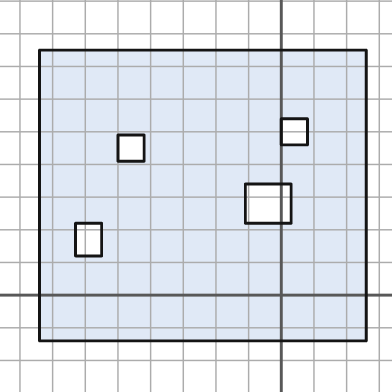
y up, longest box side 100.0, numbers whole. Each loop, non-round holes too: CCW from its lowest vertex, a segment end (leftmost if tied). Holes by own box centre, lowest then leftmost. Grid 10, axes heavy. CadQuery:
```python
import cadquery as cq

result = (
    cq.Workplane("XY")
    .moveTo(-74.0, -14.0)
    .lineTo(26.0, -14.0)
    .lineTo(26.0, 75.0)
    .lineTo(-74.0, 75.0)
    .close()
    .moveTo(-63.0, 12.0)
    .lineTo(-55.0, 12.0)
    .lineTo(-55.0, 22.0)
    .lineTo(-63.0, 22.0)
    .close()
    .moveTo(-11.0, 22.0)
    .lineTo(3.0, 22.0)
    .lineTo(3.0, 34.0)
    .lineTo(-11.0, 34.0)
    .close()
    .moveTo(-50.0, 41.0)
    .lineTo(-42.0, 41.0)
    .lineTo(-42.0, 49.0)
    .lineTo(-50.0, 49.0)
    .close()
    .moveTo(0.0, 46.0)
    .lineTo(8.0, 46.0)
    .lineTo(8.0, 54.0)
    .lineTo(0.0, 54.0)
    .close()
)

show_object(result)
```